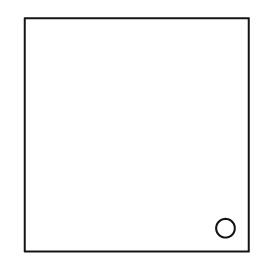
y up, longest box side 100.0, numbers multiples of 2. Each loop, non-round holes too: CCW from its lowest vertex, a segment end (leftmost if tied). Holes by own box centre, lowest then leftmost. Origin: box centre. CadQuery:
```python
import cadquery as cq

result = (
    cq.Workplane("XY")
    .moveTo(-48.0, -50.0)
    .lineTo(48.0, -50.0)
    .lineTo(48.0, 50.0)
    .lineTo(-48.0, 50.0)
    .close()
    .moveTo(38.0, -40.0)
    .circle(4.0)
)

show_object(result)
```